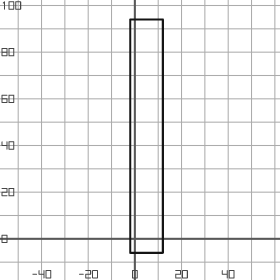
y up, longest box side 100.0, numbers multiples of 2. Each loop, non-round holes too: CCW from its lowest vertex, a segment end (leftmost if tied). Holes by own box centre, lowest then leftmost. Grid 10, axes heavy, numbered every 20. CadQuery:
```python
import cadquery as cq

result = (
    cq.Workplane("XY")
    .moveTo(-2.0, -6.0)
    .lineTo(12.0, -6.0)
    .lineTo(12.0, 94.0)
    .lineTo(-2.0, 94.0)
    .close()
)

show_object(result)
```